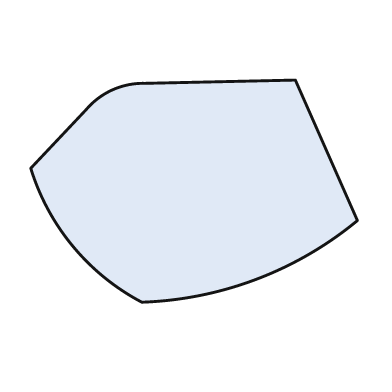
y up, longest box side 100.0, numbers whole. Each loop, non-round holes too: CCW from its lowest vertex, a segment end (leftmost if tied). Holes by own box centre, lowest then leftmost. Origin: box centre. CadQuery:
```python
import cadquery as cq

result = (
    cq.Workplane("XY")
    .moveTo(-16.0, -34.0)
    .threePointArc((19.0, -27.0), (50.0, -9.0))
    .lineTo(31.0, 34.0)
    .lineTo(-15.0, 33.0)
    .threePointArc((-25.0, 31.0), (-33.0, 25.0))
    .lineTo(-50.0, 7.0)
    .threePointArc((-37.0, -17.0), (-16.0, -34.0))
    .close()
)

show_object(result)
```